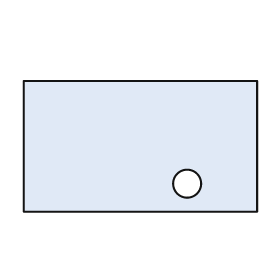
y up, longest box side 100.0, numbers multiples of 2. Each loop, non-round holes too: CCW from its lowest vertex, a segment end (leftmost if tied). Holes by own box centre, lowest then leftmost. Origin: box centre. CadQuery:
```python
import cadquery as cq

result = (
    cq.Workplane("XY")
    .moveTo(-50.0, -28.0)
    .lineTo(50.0, -28.0)
    .lineTo(50.0, 28.0)
    .lineTo(-50.0, 28.0)
    .close()
    .moveTo(20.0, -16.0)
    .circle(6.0)
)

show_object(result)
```